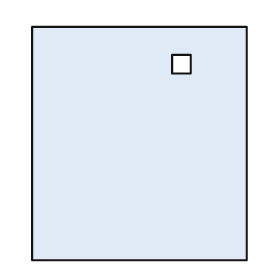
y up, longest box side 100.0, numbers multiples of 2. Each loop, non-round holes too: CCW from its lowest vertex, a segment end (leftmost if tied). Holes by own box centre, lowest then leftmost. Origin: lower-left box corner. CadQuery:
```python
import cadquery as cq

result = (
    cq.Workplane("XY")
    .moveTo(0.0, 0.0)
    .lineTo(92.0, 0.0)
    .lineTo(92.0, 100.0)
    .lineTo(0.0, 100.0)
    .close()
    .moveTo(60.0, 80.0)
    .lineTo(68.0, 80.0)
    .lineTo(68.0, 88.0)
    .lineTo(60.0, 88.0)
    .close()
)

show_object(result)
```